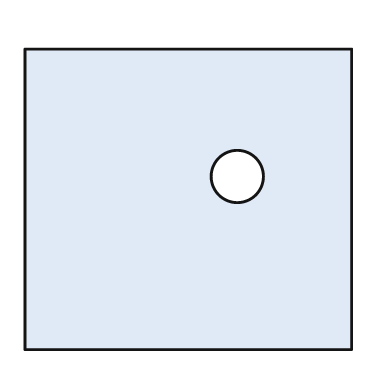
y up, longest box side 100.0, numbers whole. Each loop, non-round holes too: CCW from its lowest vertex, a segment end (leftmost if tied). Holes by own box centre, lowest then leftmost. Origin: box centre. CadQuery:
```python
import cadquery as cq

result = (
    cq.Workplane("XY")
    .moveTo(-50.0, -46.0)
    .lineTo(50.0, -46.0)
    .lineTo(50.0, 46.0)
    .lineTo(-50.0, 46.0)
    .close()
    .moveTo(15.0, 7.0)
    .circle(8.0)
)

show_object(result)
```